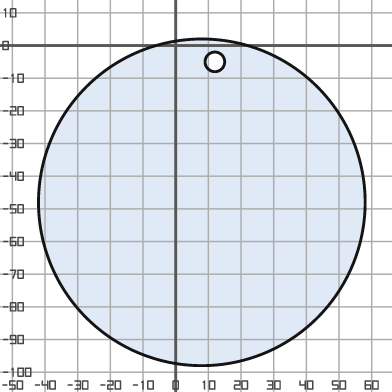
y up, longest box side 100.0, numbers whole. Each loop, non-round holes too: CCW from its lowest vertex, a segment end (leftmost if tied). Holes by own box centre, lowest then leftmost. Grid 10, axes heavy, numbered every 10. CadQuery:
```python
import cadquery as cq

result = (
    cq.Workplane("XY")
    .moveTo(8.0, -48.0)
    .circle(50.0)
    .moveTo(12.0, -5.0)
    .circle(3.0)
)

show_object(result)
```